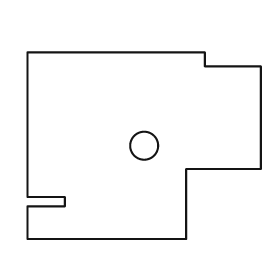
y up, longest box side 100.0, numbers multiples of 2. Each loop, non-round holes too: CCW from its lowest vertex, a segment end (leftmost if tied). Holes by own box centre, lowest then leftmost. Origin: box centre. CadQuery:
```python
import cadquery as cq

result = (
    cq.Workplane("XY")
    .moveTo(-50.0, -40.0)
    .lineTo(18.0, -40.0)
    .lineTo(18.0, -10.0)
    .lineTo(50.0, -10.0)
    .lineTo(50.0, 34.0)
    .lineTo(26.0, 34.0)
    .lineTo(26.0, 40.0)
    .lineTo(-50.0, 40.0)
    .lineTo(-50.0, -22.0)
    .lineTo(-34.0, -22.0)
    .lineTo(-34.0, -26.0)
    .lineTo(-50.0, -26.0)
    .close()
    .moveTo(0.0, 0.0)
    .circle(6.0)
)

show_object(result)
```